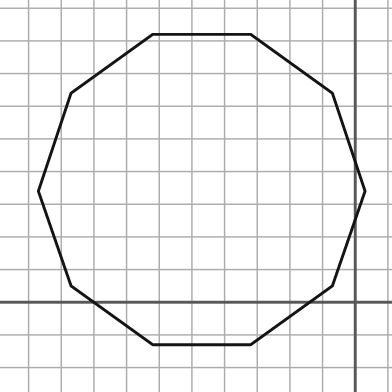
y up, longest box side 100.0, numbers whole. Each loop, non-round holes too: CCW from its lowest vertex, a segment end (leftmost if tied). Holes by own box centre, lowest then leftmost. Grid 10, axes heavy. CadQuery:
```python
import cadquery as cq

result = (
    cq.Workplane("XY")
    .moveTo(-62.0, -13.0)
    .lineTo(-32.0, -13.0)
    .lineTo(-7.0, 5.0)
    .lineTo(3.0, 34.0)
    .lineTo(-7.0, 64.0)
    .lineTo(-32.0, 82.0)
    .lineTo(-62.0, 82.0)
    .lineTo(-87.0, 64.0)
    .lineTo(-97.0, 34.0)
    .lineTo(-87.0, 5.0)
    .close()
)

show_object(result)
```